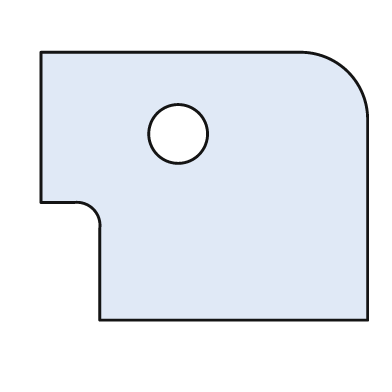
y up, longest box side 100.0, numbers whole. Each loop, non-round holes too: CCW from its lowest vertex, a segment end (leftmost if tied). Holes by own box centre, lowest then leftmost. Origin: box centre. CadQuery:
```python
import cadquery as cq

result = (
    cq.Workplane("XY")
    .moveTo(-32.0, -41.0)
    .lineTo(50.0, -41.0)
    .lineTo(50.0, 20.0)
    .threePointArc((44.0, 35.0), (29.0, 41.0))
    .lineTo(-50.0, 41.0)
    .lineTo(-50.0, -5.0)
    .lineTo(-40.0, -5.0)
    .threePointArc((-34.0, -7.0), (-32.0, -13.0))
    .close()
    .moveTo(-8.0, 16.0)
    .circle(9.0)
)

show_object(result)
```